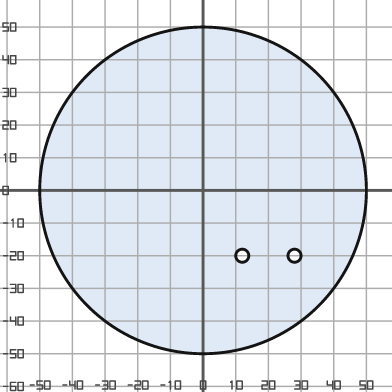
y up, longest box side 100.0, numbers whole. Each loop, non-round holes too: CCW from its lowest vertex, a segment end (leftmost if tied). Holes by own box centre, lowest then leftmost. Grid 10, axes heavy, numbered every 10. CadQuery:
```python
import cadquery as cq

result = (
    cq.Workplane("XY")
    .moveTo(0.0, 0.0)
    .circle(50.0)
    .moveTo(12.0, -20.0)
    .circle(2.0)
    .moveTo(28.0, -20.0)
    .circle(2.0)
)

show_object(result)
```